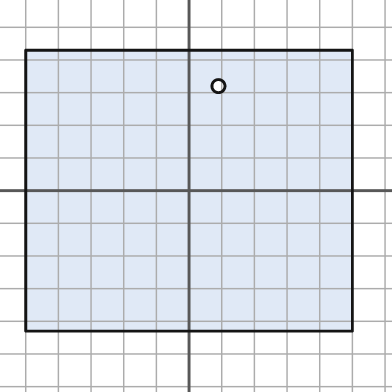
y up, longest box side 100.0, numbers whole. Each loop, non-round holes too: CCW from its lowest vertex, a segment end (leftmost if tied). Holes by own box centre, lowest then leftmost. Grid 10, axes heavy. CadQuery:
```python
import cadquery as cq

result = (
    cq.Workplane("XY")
    .moveTo(-50.0, -43.0)
    .lineTo(50.0, -43.0)
    .lineTo(50.0, 43.0)
    .lineTo(-50.0, 43.0)
    .close()
    .moveTo(9.0, 32.0)
    .circle(2.0)
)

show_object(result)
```